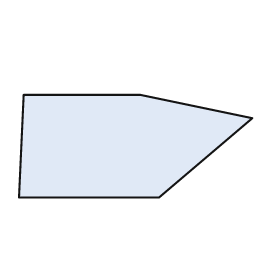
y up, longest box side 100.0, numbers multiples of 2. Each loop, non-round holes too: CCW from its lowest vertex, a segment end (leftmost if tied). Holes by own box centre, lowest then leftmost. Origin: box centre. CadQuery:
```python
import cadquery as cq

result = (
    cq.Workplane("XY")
    .moveTo(-50.0, -22.0)
    .lineTo(10.0, -22.0)
    .lineTo(50.0, 12.0)
    .lineTo(2.0, 22.0)
    .lineTo(-48.0, 22.0)
    .close()
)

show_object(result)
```